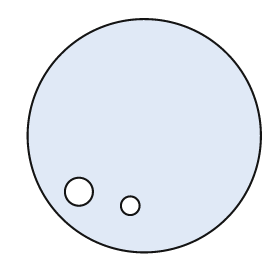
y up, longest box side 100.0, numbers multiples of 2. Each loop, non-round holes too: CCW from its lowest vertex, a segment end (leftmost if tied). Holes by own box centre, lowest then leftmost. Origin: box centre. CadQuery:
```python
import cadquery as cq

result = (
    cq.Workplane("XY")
    .moveTo(0.0, 0.0)
    .circle(50.0)
    .moveTo(-6.0, -30.0)
    .circle(4.0)
    .moveTo(-28.0, -24.0)
    .circle(6.0)
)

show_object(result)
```